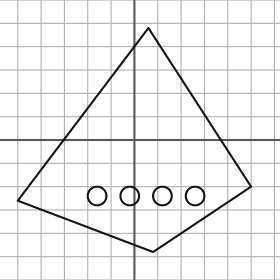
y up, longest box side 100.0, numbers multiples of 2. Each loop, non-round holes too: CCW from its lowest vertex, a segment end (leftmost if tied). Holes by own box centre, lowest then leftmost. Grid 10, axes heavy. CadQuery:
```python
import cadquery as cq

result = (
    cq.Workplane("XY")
    .moveTo(8.0, -48.0)
    .lineTo(50.0, -20.0)
    .lineTo(6.0, 48.0)
    .lineTo(-50.0, -26.0)
    .close()
    .moveTo(-16.0, -24.0)
    .circle(4.0)
    .moveTo(-2.0, -24.0)
    .circle(4.0)
    .moveTo(12.0, -24.0)
    .circle(4.0)
    .moveTo(26.0, -24.0)
    .circle(4.0)
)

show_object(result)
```